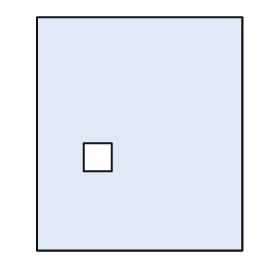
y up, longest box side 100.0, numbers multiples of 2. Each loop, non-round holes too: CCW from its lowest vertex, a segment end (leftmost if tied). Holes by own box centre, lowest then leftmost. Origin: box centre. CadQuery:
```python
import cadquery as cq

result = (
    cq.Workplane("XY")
    .moveTo(-44.0, -50.0)
    .lineTo(44.0, -50.0)
    .lineTo(44.0, 50.0)
    .lineTo(-44.0, 50.0)
    .close()
    .moveTo(-24.0, -16.0)
    .lineTo(-12.0, -16.0)
    .lineTo(-12.0, -4.0)
    .lineTo(-24.0, -4.0)
    .close()
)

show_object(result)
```